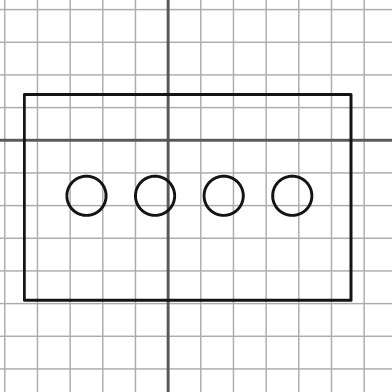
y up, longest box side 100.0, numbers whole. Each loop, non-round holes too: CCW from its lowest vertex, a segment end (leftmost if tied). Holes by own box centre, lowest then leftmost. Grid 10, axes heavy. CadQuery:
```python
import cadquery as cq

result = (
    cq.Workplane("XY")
    .moveTo(-44.0, -49.0)
    .lineTo(56.0, -49.0)
    .lineTo(56.0, 14.0)
    .lineTo(-44.0, 14.0)
    .close()
    .moveTo(-25.0, -17.0)
    .circle(6.0)
    .moveTo(-4.0, -17.0)
    .circle(6.0)
    .moveTo(17.0, -17.0)
    .circle(6.0)
    .moveTo(38.0, -17.0)
    .circle(6.0)
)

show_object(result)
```